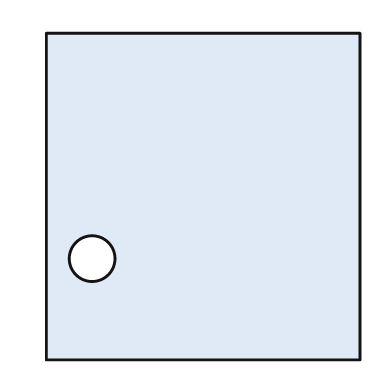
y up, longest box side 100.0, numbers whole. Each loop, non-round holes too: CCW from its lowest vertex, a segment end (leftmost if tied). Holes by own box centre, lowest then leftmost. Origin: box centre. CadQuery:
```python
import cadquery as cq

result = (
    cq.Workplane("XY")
    .moveTo(-48.0, -50.0)
    .lineTo(48.0, -50.0)
    .lineTo(48.0, 50.0)
    .lineTo(-48.0, 50.0)
    .close()
    .moveTo(-34.0, -19.0)
    .circle(7.0)
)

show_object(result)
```